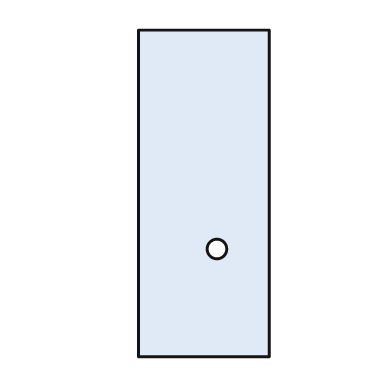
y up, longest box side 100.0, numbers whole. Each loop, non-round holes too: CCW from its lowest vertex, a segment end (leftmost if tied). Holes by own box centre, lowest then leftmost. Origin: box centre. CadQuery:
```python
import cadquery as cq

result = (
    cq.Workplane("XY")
    .moveTo(-20.0, -50.0)
    .lineTo(20.0, -50.0)
    .lineTo(20.0, 50.0)
    .lineTo(-20.0, 50.0)
    .close()
    .moveTo(4.0, -17.0)
    .circle(3.0)
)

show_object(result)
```